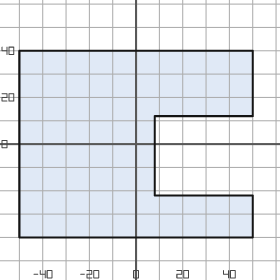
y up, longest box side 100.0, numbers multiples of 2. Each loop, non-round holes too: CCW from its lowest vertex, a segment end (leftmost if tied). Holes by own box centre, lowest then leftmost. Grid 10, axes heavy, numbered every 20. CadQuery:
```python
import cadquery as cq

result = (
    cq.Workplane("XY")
    .moveTo(-50.0, -40.0)
    .lineTo(50.0, -40.0)
    .lineTo(50.0, -22.0)
    .lineTo(8.0, -22.0)
    .lineTo(8.0, 12.0)
    .lineTo(50.0, 12.0)
    .lineTo(50.0, 40.0)
    .lineTo(-50.0, 40.0)
    .close()
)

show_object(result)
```